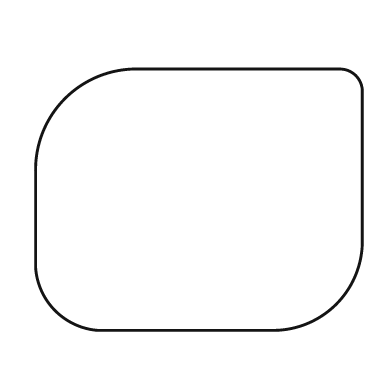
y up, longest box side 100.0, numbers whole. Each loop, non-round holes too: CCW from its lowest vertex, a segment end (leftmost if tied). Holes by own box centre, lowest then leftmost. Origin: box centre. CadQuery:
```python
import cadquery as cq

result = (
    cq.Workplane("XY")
    .moveTo(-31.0, -40.0)
    .lineTo(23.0, -40.0)
    .threePointArc((42.0, -32.0), (50.0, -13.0))
    .lineTo(50.0, 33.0)
    .threePointArc((48.0, 38.0), (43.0, 40.0))
    .lineTo(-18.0, 40.0)
    .threePointArc((-41.0, 31.0), (-50.0, 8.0))
    .lineTo(-50.0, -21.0)
    .threePointArc((-44.0, -34.0), (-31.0, -40.0))
    .close()
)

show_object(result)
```